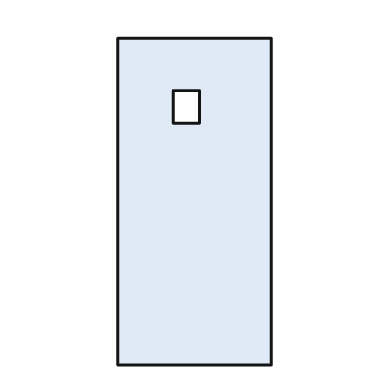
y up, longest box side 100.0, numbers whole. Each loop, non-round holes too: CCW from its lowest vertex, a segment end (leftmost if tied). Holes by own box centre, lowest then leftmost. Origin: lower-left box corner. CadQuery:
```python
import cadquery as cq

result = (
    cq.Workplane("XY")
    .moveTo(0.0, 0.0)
    .lineTo(47.0, 0.0)
    .lineTo(47.0, 100.0)
    .lineTo(0.0, 100.0)
    .close()
    .moveTo(17.0, 74.0)
    .lineTo(25.0, 74.0)
    .lineTo(25.0, 84.0)
    .lineTo(17.0, 84.0)
    .close()
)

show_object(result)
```